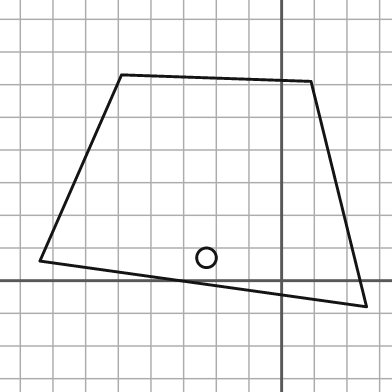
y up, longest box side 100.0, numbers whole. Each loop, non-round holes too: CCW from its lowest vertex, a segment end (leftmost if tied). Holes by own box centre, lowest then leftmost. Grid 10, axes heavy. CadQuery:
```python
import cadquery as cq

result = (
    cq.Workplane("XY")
    .moveTo(26.0, -8.0)
    .lineTo(9.0, 61.0)
    .lineTo(-49.0, 63.0)
    .lineTo(-74.0, 6.0)
    .close()
    .moveTo(-23.0, 7.0)
    .circle(3.0)
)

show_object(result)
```